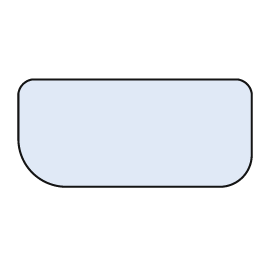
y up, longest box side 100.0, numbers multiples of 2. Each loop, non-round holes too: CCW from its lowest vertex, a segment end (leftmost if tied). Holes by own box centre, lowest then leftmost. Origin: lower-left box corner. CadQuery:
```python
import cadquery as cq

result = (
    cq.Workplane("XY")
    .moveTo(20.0, 0.0)
    .lineTo(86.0, 0.0)
    .threePointArc((96.0, 4.0), (100.0, 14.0))
    .lineTo(100.0, 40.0)
    .threePointArc((98.0, 44.0), (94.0, 46.0))
    .lineTo(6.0, 46.0)
    .threePointArc((2.0, 44.0), (0.0, 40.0))
    .lineTo(0.0, 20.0)
    .threePointArc((6.0, 6.0), (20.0, 0.0))
    .close()
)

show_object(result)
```